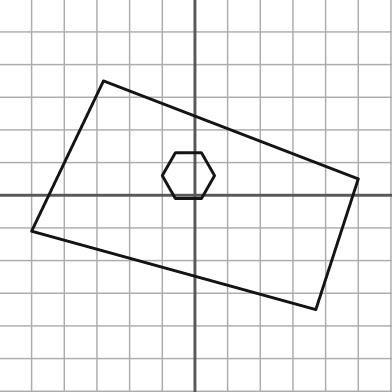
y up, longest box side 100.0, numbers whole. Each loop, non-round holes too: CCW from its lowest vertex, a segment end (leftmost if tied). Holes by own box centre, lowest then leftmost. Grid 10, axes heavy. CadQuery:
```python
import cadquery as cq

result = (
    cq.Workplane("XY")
    .moveTo(37.0, -35.0)
    .lineTo(50.0, 5.0)
    .lineTo(-28.0, 35.0)
    .lineTo(-50.0, -11.0)
    .close()
    .moveTo(-6.0, -1.0)
    .lineTo(2.0, -1.0)
    .lineTo(6.0, 6.0)
    .lineTo(2.0, 13.0)
    .lineTo(-6.0, 13.0)
    .lineTo(-10.0, 6.0)
    .close()
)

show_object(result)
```